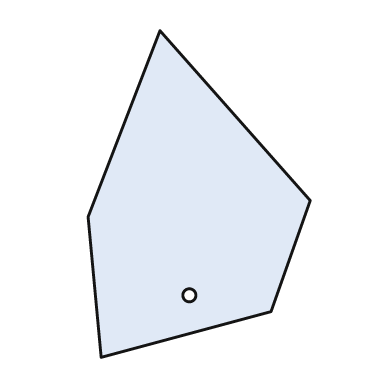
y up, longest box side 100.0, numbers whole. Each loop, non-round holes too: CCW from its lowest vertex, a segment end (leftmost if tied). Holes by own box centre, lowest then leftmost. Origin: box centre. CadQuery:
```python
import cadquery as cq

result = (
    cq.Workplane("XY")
    .moveTo(-30.0, -50.0)
    .lineTo(22.0, -36.0)
    .lineTo(34.0, -2.0)
    .lineTo(-12.0, 50.0)
    .lineTo(-34.0, -7.0)
    .close()
    .moveTo(-3.0, -31.0)
    .circle(2.0)
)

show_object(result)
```